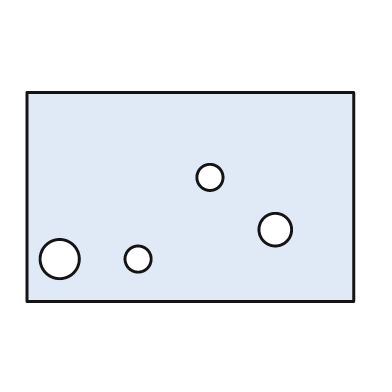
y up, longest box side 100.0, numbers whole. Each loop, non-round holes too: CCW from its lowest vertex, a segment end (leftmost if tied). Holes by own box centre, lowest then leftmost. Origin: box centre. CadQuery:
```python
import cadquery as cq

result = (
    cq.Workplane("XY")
    .moveTo(-50.0, -32.0)
    .lineTo(50.0, -32.0)
    .lineTo(50.0, 32.0)
    .lineTo(-50.0, 32.0)
    .close()
    .moveTo(-40.0, -19.0)
    .circle(6.0)
    .moveTo(-16.0, -19.0)
    .circle(4.0)
    .moveTo(26.0, -10.0)
    .circle(5.0)
    .moveTo(6.0, 6.0)
    .circle(4.0)
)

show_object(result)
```